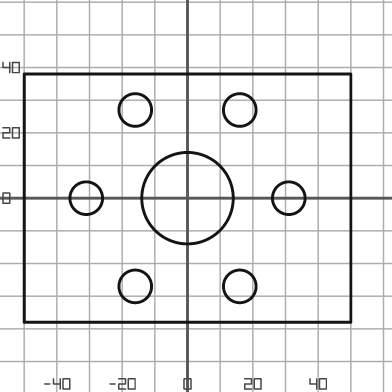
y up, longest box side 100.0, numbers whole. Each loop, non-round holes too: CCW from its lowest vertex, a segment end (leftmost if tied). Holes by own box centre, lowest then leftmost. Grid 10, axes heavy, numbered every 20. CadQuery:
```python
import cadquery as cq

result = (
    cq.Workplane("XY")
    .moveTo(-50.0, -38.0)
    .lineTo(50.0, -38.0)
    .lineTo(50.0, 38.0)
    .lineTo(-50.0, 38.0)
    .close()
    .moveTo(-16.0, -27.0)
    .circle(5.0)
    .moveTo(16.0, -27.0)
    .circle(5.0)
    .moveTo(-31.0, 0.0)
    .circle(5.0)
    .moveTo(0.0, 0.0)
    .circle(14.0)
    .moveTo(31.0, 0.0)
    .circle(5.0)
    .moveTo(-16.0, 27.0)
    .circle(5.0)
    .moveTo(16.0, 27.0)
    .circle(5.0)
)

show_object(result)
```